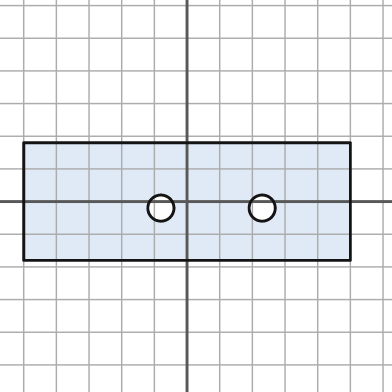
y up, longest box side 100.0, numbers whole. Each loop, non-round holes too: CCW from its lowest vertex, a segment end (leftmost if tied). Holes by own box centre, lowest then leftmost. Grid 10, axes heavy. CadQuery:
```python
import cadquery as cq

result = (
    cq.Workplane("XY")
    .moveTo(-50.0, -18.0)
    .lineTo(50.0, -18.0)
    .lineTo(50.0, 18.0)
    .lineTo(-50.0, 18.0)
    .close()
    .moveTo(-8.0, -2.0)
    .circle(4.0)
    .moveTo(23.0, -2.0)
    .circle(4.0)
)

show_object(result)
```